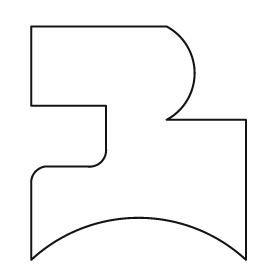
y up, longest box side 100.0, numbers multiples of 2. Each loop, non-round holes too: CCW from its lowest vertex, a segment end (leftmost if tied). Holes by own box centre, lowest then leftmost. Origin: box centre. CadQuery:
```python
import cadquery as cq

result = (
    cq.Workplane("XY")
    .moveTo(-46.0, -50.0)
    .threePointArc((0.0, -32.0), (46.0, -50.0))
    .lineTo(46.0, 10.0)
    .lineTo(12.0, 10.0)
    .threePointArc((24.0, 30.0), (12.0, 50.0))
    .lineTo(-46.0, 50.0)
    .lineTo(-46.0, 16.0)
    .lineTo(-14.0, 16.0)
    .lineTo(-14.0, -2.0)
    .threePointArc((-16.0, -8.0), (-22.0, -10.0))
    .lineTo(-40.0, -10.0)
    .threePointArc((-44.0, -12.0), (-46.0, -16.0))
    .close()
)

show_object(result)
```